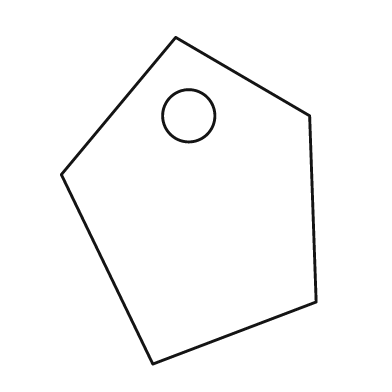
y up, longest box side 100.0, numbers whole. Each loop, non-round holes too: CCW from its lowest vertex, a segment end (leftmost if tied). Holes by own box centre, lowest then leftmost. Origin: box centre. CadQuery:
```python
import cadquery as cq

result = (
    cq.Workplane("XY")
    .moveTo(-11.0, -50.0)
    .lineTo(39.0, -31.0)
    .lineTo(37.0, 26.0)
    .lineTo(-4.0, 50.0)
    .lineTo(-39.0, 8.0)
    .close()
    .moveTo(0.0, 26.0)
    .circle(8.0)
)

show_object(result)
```